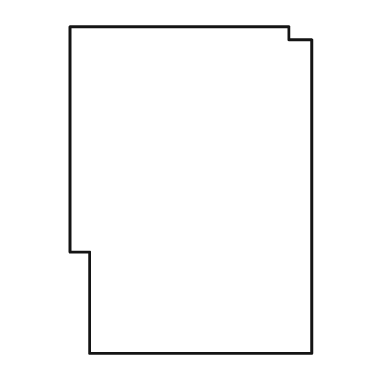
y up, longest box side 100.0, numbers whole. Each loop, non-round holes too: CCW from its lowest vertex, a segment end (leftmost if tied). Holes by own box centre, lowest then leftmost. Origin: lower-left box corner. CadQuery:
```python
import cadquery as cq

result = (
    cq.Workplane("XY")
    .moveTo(6.0, 0.0)
    .lineTo(74.0, 0.0)
    .lineTo(74.0, 96.0)
    .lineTo(67.0, 96.0)
    .lineTo(67.0, 100.0)
    .lineTo(0.0, 100.0)
    .lineTo(0.0, 31.0)
    .lineTo(6.0, 31.0)
    .close()
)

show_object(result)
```